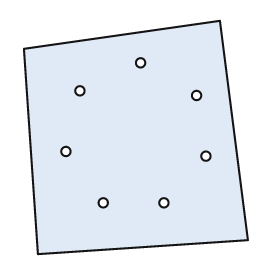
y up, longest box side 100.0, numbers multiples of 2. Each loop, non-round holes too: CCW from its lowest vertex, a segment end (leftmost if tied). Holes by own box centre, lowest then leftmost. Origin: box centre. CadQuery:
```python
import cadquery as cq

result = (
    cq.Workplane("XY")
    .moveTo(-42.0, -50.0)
    .lineTo(48.0, -44.0)
    .lineTo(36.0, 50.0)
    .lineTo(-48.0, 38.0)
    .close()
    .moveTo(-14.0, -28.0)
    .circle(2.0)
    .moveTo(12.0, -28.0)
    .circle(2.0)
    .moveTo(30.0, -8.0)
    .circle(2.0)
    .moveTo(-30.0, -6.0)
    .circle(2.0)
    .moveTo(26.0, 18.0)
    .circle(2.0)
    .moveTo(-24.0, 20.0)
    .circle(2.0)
    .moveTo(2.0, 32.0)
    .circle(2.0)
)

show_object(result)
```